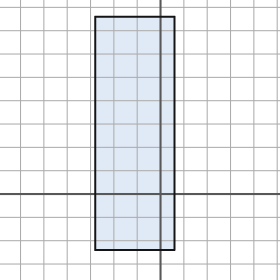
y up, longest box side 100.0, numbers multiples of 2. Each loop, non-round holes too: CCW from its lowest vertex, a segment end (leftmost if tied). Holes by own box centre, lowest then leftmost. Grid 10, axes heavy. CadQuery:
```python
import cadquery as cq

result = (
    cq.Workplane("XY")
    .moveTo(-28.0, -24.0)
    .lineTo(6.0, -24.0)
    .lineTo(6.0, 76.0)
    .lineTo(-28.0, 76.0)
    .close()
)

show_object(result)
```